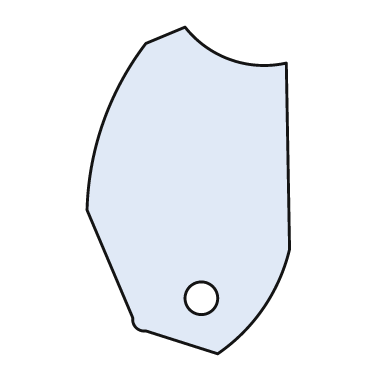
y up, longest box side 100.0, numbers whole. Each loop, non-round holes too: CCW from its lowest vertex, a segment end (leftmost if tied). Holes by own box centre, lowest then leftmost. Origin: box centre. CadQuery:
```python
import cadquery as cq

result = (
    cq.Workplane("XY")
    .moveTo(9.0, -50.0)
    .threePointArc((23.0, -36.0), (31.0, -18.0))
    .lineTo(30.0, 39.0)
    .threePointArc((13.0, 40.0), (-1.0, 50.0))
    .lineTo(-13.0, 45.0)
    .threePointArc((-26.0, 21.0), (-31.0, -6.0))
    .lineTo(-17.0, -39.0)
    .threePointArc((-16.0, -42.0), (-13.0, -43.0))
    .close()
    .moveTo(4.0, -33.0)
    .circle(5.0)
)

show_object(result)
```